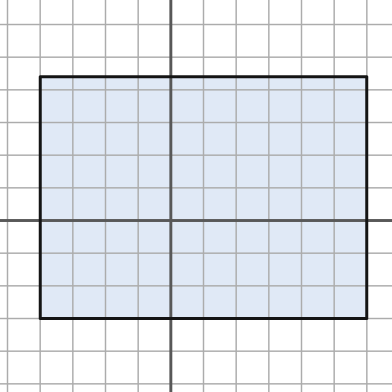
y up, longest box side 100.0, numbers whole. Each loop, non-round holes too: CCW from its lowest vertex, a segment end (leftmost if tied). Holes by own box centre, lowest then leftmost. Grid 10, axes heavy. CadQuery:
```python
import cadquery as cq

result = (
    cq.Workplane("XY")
    .moveTo(-40.0, -30.0)
    .lineTo(60.0, -30.0)
    .lineTo(60.0, 44.0)
    .lineTo(-40.0, 44.0)
    .close()
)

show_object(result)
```